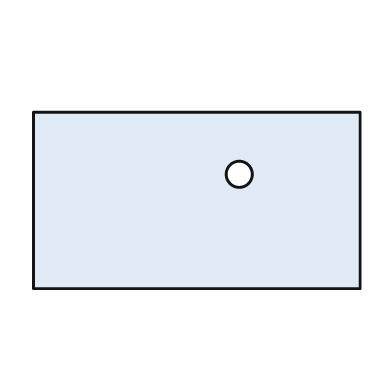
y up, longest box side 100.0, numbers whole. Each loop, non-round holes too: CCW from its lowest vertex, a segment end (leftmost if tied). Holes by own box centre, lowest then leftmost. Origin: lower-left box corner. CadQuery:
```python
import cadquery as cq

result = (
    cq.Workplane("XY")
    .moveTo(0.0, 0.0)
    .lineTo(100.0, 0.0)
    .lineTo(100.0, 54.0)
    .lineTo(0.0, 54.0)
    .close()
    .moveTo(63.0, 35.0)
    .circle(4.0)
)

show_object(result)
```